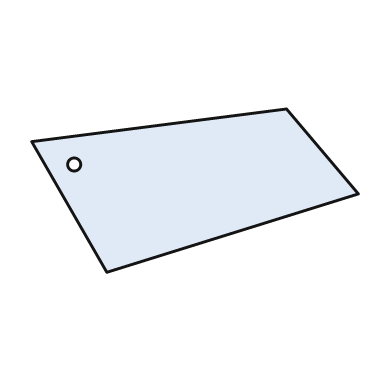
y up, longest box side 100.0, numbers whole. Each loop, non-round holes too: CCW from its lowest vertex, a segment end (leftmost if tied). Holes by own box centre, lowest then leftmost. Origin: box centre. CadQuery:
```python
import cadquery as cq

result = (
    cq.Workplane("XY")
    .moveTo(-27.0, -25.0)
    .lineTo(50.0, -1.0)
    .lineTo(28.0, 25.0)
    .lineTo(-50.0, 15.0)
    .close()
    .moveTo(-37.0, 8.0)
    .circle(2.0)
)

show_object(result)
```